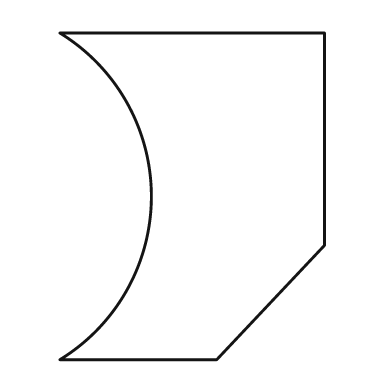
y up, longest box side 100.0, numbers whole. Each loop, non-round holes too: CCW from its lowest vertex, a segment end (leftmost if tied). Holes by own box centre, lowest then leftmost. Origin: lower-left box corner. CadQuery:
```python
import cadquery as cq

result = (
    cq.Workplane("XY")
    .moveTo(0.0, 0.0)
    .lineTo(48.0, 0.0)
    .lineTo(81.0, 35.0)
    .lineTo(81.0, 100.0)
    .lineTo(0.0, 100.0)
    .threePointArc((28.0, 50.0), (0.0, 0.0))
    .close()
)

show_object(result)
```